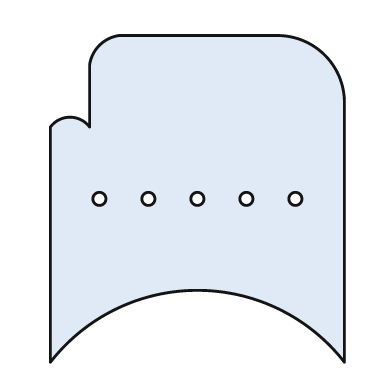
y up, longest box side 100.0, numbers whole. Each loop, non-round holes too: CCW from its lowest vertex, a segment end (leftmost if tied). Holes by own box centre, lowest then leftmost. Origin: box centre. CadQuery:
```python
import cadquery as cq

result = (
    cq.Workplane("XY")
    .moveTo(-45.0, -50.0)
    .threePointArc((0.0, -28.0), (45.0, -50.0))
    .lineTo(45.0, 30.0)
    .threePointArc((39.0, 44.0), (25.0, 50.0))
    .lineTo(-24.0, 50.0)
    .threePointArc((-30.0, 47.0), (-33.0, 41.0))
    .lineTo(-33.0, 22.0)
    .threePointArc((-39.0, 25.0), (-45.0, 22.0))
    .close()
    .moveTo(-30.0, 0.0)
    .circle(2.0)
    .moveTo(-15.0, 0.0)
    .circle(2.0)
    .moveTo(0.0, 0.0)
    .circle(2.0)
    .moveTo(15.0, 0.0)
    .circle(2.0)
    .moveTo(30.0, 0.0)
    .circle(2.0)
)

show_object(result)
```